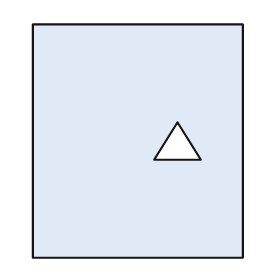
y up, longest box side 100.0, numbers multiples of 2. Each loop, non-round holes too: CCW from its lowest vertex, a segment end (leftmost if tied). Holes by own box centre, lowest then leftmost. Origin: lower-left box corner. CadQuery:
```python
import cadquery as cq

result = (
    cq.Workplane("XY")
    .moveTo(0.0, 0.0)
    .lineTo(90.0, 0.0)
    .lineTo(90.0, 100.0)
    .lineTo(0.0, 100.0)
    .close()
    .moveTo(52.0, 42.0)
    .lineTo(72.0, 42.0)
    .lineTo(62.0, 58.0)
    .close()
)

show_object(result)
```